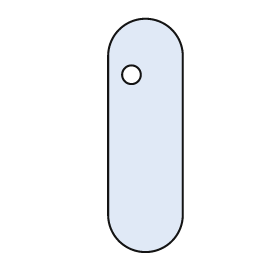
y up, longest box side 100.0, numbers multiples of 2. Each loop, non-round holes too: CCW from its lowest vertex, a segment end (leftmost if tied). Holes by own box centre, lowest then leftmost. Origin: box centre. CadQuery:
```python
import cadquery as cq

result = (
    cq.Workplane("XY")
    .moveTo(-16.0, -34.0)
    .threePointArc((0.0, -50.0), (16.0, -34.0))
    .lineTo(16.0, 34.0)
    .threePointArc((0.0, 50.0), (-16.0, 34.0))
    .close()
    .moveTo(-6.0, 26.0)
    .circle(4.0)
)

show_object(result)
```